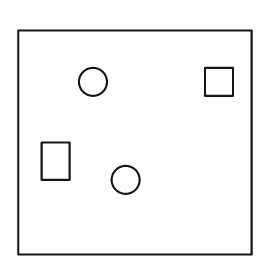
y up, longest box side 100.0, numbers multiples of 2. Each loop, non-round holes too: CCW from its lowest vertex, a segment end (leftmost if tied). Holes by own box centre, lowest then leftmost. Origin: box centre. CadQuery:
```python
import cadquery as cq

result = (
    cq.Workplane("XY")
    .moveTo(-50.0, -48.0)
    .lineTo(50.0, -48.0)
    .lineTo(50.0, 48.0)
    .lineTo(-50.0, 48.0)
    .close()
    .moveTo(-4.0, -16.0)
    .circle(6.0)
    .moveTo(-40.0, -16.0)
    .lineTo(-28.0, -16.0)
    .lineTo(-28.0, 0.0)
    .lineTo(-40.0, 0.0)
    .close()
    .moveTo(-18.0, 26.0)
    .circle(6.0)
    .moveTo(30.0, 20.0)
    .lineTo(42.0, 20.0)
    .lineTo(42.0, 32.0)
    .lineTo(30.0, 32.0)
    .close()
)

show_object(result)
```